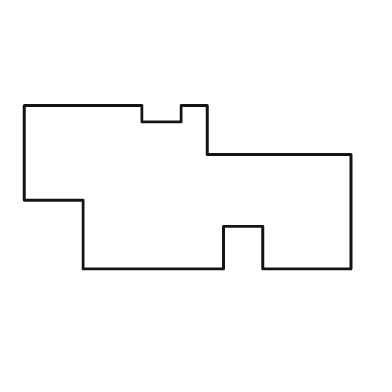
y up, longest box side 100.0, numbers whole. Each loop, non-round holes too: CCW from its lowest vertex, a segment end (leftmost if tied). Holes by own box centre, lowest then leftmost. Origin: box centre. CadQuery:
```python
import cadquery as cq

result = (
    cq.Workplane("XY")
    .moveTo(-32.0, -25.0)
    .lineTo(11.0, -25.0)
    .lineTo(11.0, -12.0)
    .lineTo(23.0, -12.0)
    .lineTo(23.0, -25.0)
    .lineTo(50.0, -25.0)
    .lineTo(50.0, 10.0)
    .lineTo(6.0, 10.0)
    .lineTo(6.0, 25.0)
    .lineTo(-2.0, 25.0)
    .lineTo(-2.0, 20.0)
    .lineTo(-14.0, 20.0)
    .lineTo(-14.0, 25.0)
    .lineTo(-50.0, 25.0)
    .lineTo(-50.0, -4.0)
    .lineTo(-32.0, -4.0)
    .close()
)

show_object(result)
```